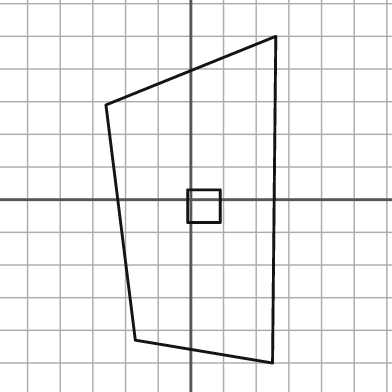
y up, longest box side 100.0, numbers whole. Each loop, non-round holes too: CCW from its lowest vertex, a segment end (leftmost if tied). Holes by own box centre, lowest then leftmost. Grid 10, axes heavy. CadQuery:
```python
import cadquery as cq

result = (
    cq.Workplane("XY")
    .moveTo(25.0, -50.0)
    .lineTo(26.0, 50.0)
    .lineTo(-26.0, 29.0)
    .lineTo(-17.0, -43.0)
    .close()
    .moveTo(-1.0, -7.0)
    .lineTo(9.0, -7.0)
    .lineTo(9.0, 3.0)
    .lineTo(-1.0, 3.0)
    .close()
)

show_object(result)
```